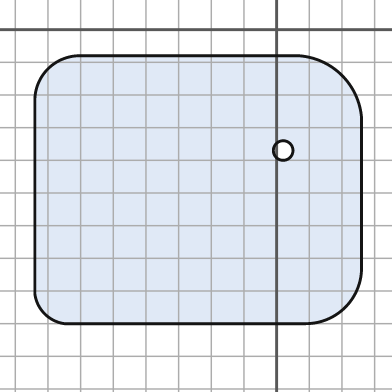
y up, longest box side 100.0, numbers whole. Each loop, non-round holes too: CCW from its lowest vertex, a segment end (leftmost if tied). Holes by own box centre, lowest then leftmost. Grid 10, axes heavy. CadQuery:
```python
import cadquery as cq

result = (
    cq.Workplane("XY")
    .moveTo(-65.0, -90.0)
    .lineTo(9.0, -90.0)
    .threePointArc((21.0, -85.0), (26.0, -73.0))
    .lineTo(26.0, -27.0)
    .threePointArc((20.0, -14.0), (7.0, -8.0))
    .lineTo(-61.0, -8.0)
    .threePointArc((-70.0, -12.0), (-74.0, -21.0))
    .lineTo(-74.0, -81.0)
    .threePointArc((-71.0, -87.0), (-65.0, -90.0))
    .close()
    .moveTo(2.0, -37.0)
    .circle(3.0)
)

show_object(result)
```